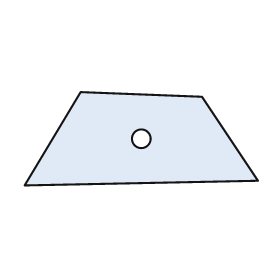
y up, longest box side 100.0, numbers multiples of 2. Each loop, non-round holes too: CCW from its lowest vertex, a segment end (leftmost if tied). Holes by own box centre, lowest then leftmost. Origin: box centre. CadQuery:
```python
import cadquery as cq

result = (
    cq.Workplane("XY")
    .moveTo(-50.0, -20.0)
    .lineTo(50.0, -18.0)
    .lineTo(26.0, 18.0)
    .lineTo(-26.0, 20.0)
    .close()
    .moveTo(0.0, 0.0)
    .circle(4.0)
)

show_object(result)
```